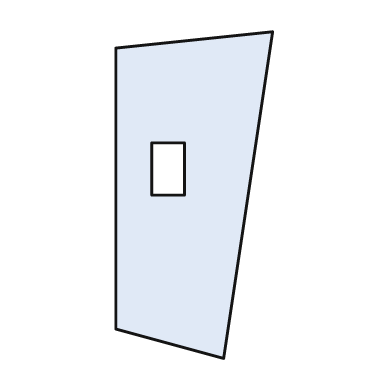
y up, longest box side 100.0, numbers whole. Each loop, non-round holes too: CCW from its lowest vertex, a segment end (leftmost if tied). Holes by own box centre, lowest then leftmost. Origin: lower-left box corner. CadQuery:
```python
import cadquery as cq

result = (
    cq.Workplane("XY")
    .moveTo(33.0, 0.0)
    .lineTo(48.0, 100.0)
    .lineTo(0.0, 95.0)
    .lineTo(0.0, 9.0)
    .close()
    .moveTo(11.0, 50.0)
    .lineTo(21.0, 50.0)
    .lineTo(21.0, 66.0)
    .lineTo(11.0, 66.0)
    .close()
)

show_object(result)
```